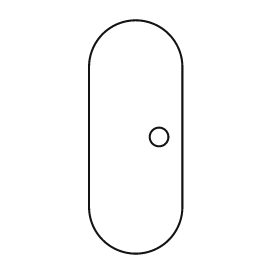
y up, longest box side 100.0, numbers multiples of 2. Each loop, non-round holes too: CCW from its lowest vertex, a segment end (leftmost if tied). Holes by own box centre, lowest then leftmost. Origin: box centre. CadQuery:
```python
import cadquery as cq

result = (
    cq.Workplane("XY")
    .moveTo(-20.0, -30.0)
    .threePointArc((0.0, -50.0), (20.0, -30.0))
    .lineTo(20.0, 30.0)
    .threePointArc((0.0, 50.0), (-20.0, 30.0))
    .close()
    .moveTo(10.0, 0.0)
    .circle(4.0)
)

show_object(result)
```